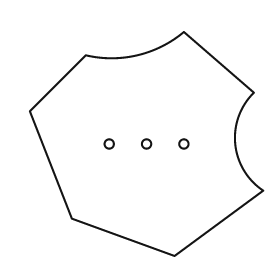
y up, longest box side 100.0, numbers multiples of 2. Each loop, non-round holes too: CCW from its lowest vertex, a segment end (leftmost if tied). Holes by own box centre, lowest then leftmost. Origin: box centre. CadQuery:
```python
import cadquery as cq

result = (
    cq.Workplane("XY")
    .moveTo(12.0, -48.0)
    .lineTo(50.0, -20.0)
    .threePointArc((38.0, 0.0), (46.0, 22.0))
    .lineTo(16.0, 48.0)
    .threePointArc((-4.0, 38.0), (-26.0, 38.0))
    .lineTo(-50.0, 14.0)
    .lineTo(-32.0, -32.0)
    .close()
    .moveTo(-16.0, 0.0)
    .circle(2.0)
    .moveTo(0.0, 0.0)
    .circle(2.0)
    .moveTo(16.0, 0.0)
    .circle(2.0)
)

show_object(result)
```